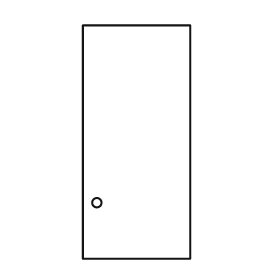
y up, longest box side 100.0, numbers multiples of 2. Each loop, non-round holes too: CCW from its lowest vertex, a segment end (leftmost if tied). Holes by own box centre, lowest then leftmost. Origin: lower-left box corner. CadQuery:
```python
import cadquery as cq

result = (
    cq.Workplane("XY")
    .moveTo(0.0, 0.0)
    .lineTo(46.0, 0.0)
    .lineTo(46.0, 100.0)
    .lineTo(0.0, 100.0)
    .close()
    .moveTo(6.0, 24.0)
    .circle(2.0)
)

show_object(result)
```